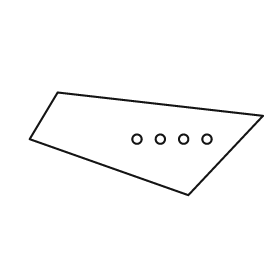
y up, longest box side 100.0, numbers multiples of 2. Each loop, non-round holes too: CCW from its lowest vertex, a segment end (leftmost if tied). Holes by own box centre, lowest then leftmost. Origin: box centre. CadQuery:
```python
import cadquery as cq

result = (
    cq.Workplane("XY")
    .moveTo(18.0, -22.0)
    .lineTo(50.0, 12.0)
    .lineTo(-38.0, 22.0)
    .lineTo(-50.0, 2.0)
    .close()
    .moveTo(-4.0, 2.0)
    .circle(2.0)
    .moveTo(6.0, 2.0)
    .circle(2.0)
    .moveTo(16.0, 2.0)
    .circle(2.0)
    .moveTo(26.0, 2.0)
    .circle(2.0)
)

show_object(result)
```